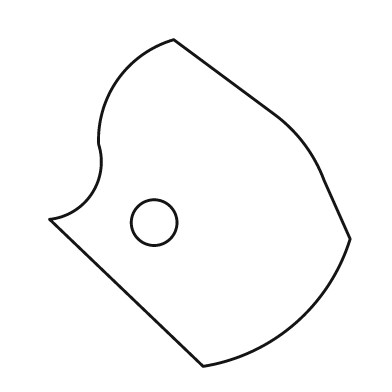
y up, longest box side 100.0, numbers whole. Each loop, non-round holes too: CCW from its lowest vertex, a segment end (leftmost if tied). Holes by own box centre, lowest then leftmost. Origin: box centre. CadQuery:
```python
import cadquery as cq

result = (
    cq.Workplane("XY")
    .moveTo(1.0, -50.0)
    .threePointArc((29.0, -37.0), (46.0, -11.0))
    .lineTo(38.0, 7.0)
    .threePointArc((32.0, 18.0), (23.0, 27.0))
    .lineTo(-8.0, 50.0)
    .threePointArc((-25.0, 38.0), (-31.0, 18.0))
    .threePointArc((-33.0, 3.0), (-46.0, -5.0))
    .close()
    .moveTo(-14.0, -6.0)
    .circle(7.0)
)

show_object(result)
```